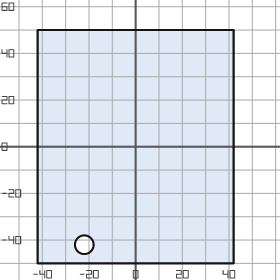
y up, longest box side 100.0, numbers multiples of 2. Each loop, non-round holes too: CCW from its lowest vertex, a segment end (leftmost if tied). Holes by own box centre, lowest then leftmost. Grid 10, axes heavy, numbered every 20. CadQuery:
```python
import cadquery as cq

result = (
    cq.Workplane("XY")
    .moveTo(-42.0, -50.0)
    .lineTo(42.0, -50.0)
    .lineTo(42.0, 50.0)
    .lineTo(-42.0, 50.0)
    .close()
    .moveTo(-22.0, -42.0)
    .circle(4.0)
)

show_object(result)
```